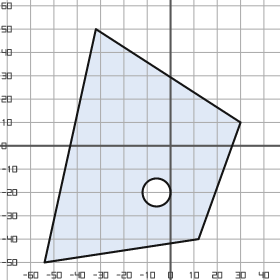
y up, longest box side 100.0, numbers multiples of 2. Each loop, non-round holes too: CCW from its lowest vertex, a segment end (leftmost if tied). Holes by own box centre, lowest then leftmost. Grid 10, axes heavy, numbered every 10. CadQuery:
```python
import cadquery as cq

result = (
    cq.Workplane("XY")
    .moveTo(-54.0, -50.0)
    .lineTo(12.0, -40.0)
    .lineTo(30.0, 10.0)
    .lineTo(-32.0, 50.0)
    .close()
    .moveTo(-6.0, -20.0)
    .circle(6.0)
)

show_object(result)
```